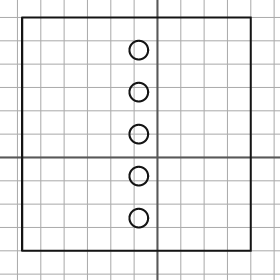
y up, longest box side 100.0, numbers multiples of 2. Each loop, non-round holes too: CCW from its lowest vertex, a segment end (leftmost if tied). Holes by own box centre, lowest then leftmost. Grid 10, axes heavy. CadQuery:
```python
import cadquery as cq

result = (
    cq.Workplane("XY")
    .moveTo(-58.0, -40.0)
    .lineTo(40.0, -40.0)
    .lineTo(40.0, 60.0)
    .lineTo(-58.0, 60.0)
    .close()
    .moveTo(-8.0, -26.0)
    .circle(4.0)
    .moveTo(-8.0, -8.0)
    .circle(4.0)
    .moveTo(-8.0, 10.0)
    .circle(4.0)
    .moveTo(-8.0, 28.0)
    .circle(4.0)
    .moveTo(-8.0, 46.0)
    .circle(4.0)
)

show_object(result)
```